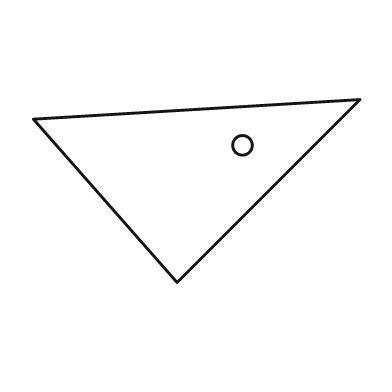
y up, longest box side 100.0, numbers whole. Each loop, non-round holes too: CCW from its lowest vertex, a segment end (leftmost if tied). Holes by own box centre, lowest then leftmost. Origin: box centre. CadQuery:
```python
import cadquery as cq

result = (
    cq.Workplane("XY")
    .moveTo(-6.0, -28.0)
    .lineTo(50.0, 28.0)
    .lineTo(-50.0, 22.0)
    .close()
    .moveTo(14.0, 14.0)
    .circle(3.0)
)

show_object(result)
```